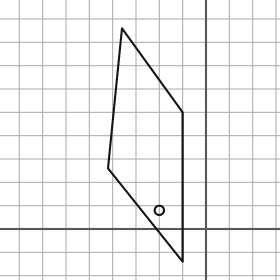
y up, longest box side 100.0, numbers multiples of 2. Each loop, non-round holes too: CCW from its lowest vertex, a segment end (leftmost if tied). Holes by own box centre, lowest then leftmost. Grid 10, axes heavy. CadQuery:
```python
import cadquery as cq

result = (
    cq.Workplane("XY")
    .moveTo(-10.0, -14.0)
    .lineTo(-10.0, 50.0)
    .lineTo(-36.0, 86.0)
    .lineTo(-42.0, 26.0)
    .close()
    .moveTo(-20.0, 8.0)
    .circle(2.0)
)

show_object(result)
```